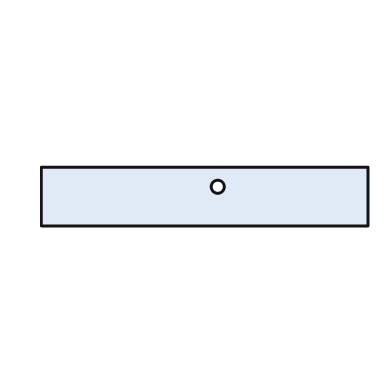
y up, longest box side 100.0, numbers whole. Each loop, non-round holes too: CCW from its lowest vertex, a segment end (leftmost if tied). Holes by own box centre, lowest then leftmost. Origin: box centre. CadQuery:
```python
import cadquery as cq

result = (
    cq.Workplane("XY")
    .moveTo(-50.0, -9.0)
    .lineTo(50.0, -9.0)
    .lineTo(50.0, 9.0)
    .lineTo(-50.0, 9.0)
    .close()
    .moveTo(4.0, 3.0)
    .circle(2.0)
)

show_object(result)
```